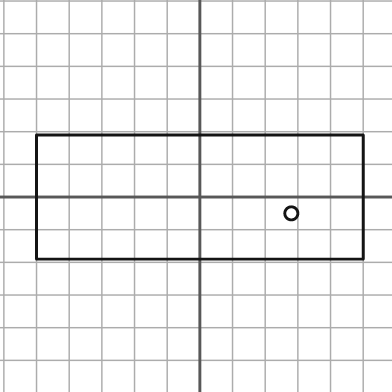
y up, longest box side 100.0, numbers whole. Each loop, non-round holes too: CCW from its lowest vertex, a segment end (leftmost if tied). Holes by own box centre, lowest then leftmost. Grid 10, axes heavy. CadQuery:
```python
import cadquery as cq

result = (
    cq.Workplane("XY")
    .moveTo(-50.0, -19.0)
    .lineTo(50.0, -19.0)
    .lineTo(50.0, 19.0)
    .lineTo(-50.0, 19.0)
    .close()
    .moveTo(28.0, -5.0)
    .circle(2.0)
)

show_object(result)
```